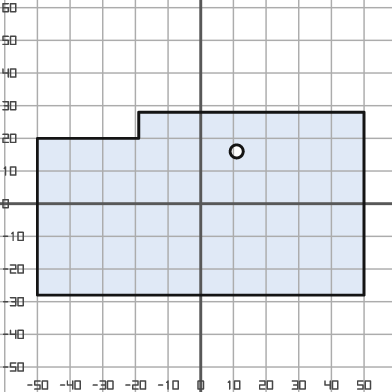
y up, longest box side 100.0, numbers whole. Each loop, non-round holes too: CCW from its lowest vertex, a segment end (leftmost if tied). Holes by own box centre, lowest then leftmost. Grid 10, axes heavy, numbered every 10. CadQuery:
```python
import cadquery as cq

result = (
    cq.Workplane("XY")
    .moveTo(-50.0, -28.0)
    .lineTo(50.0, -28.0)
    .lineTo(50.0, 28.0)
    .lineTo(-19.0, 28.0)
    .lineTo(-19.0, 20.0)
    .lineTo(-50.0, 20.0)
    .close()
    .moveTo(11.0, 16.0)
    .circle(2.0)
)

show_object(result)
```